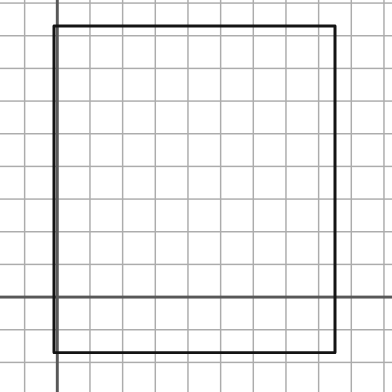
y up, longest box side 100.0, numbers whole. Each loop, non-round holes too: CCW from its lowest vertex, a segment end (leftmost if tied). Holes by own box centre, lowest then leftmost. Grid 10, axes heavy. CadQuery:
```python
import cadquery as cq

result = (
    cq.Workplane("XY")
    .moveTo(-1.0, -17.0)
    .lineTo(85.0, -17.0)
    .lineTo(85.0, 83.0)
    .lineTo(-1.0, 83.0)
    .close()
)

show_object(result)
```